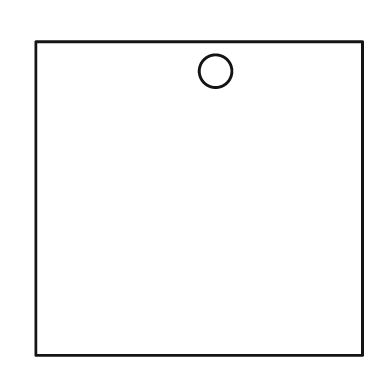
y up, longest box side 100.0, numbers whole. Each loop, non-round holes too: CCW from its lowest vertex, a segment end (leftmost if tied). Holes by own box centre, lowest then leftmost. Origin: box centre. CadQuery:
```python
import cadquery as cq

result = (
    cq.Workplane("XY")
    .moveTo(-50.0, -48.0)
    .lineTo(50.0, -48.0)
    .lineTo(50.0, 48.0)
    .lineTo(-50.0, 48.0)
    .close()
    .moveTo(5.0, 39.0)
    .circle(5.0)
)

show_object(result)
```